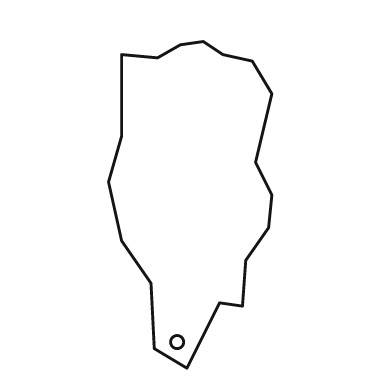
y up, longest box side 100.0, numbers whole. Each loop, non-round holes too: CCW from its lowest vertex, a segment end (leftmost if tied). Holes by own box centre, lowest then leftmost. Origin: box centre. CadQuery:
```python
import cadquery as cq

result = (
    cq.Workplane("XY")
    .moveTo(-1.0, -50.0)
    .lineTo(9.0, -30.0)
    .lineTo(16.0, -31.0)
    .lineTo(17.0, -17.0)
    .lineTo(24.0, -7.0)
    .lineTo(25.0, 3.0)
    .lineTo(20.0, 13.0)
    .lineTo(25.0, 34.0)
    .lineTo(19.0, 44.0)
    .lineTo(10.0, 46.0)
    .lineTo(4.0, 50.0)
    .lineTo(-3.0, 49.0)
    .lineTo(-10.0, 45.0)
    .lineTo(-21.0, 46.0)
    .lineTo(-21.0, 21.0)
    .lineTo(-25.0, 7.0)
    .lineTo(-21.0, -11.0)
    .lineTo(-12.0, -24.0)
    .lineTo(-11.0, -44.0)
    .close()
    .moveTo(-4.0, -42.0)
    .circle(2.0)
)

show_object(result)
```